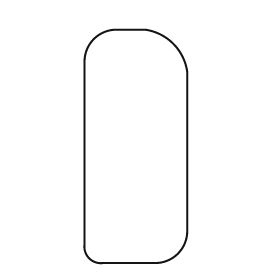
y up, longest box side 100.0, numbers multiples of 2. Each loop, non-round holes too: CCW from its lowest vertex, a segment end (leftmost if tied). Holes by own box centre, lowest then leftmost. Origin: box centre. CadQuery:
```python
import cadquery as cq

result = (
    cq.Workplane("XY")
    .moveTo(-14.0, -50.0)
    .lineTo(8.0, -50.0)
    .threePointArc((18.0, -46.0), (22.0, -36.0))
    .lineTo(22.0, 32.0)
    .threePointArc((16.0, 44.0), (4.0, 50.0))
    .lineTo(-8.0, 50.0)
    .threePointArc((-18.0, 46.0), (-22.0, 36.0))
    .lineTo(-22.0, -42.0)
    .threePointArc((-20.0, -48.0), (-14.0, -50.0))
    .close()
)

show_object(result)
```